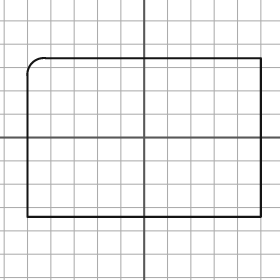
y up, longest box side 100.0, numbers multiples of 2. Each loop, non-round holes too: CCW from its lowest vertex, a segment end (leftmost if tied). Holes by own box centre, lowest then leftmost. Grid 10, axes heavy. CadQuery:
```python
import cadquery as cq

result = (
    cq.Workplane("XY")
    .moveTo(-50.0, -34.0)
    .lineTo(50.0, -34.0)
    .lineTo(50.0, 34.0)
    .lineTo(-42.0, 34.0)
    .threePointArc((-48.0, 32.0), (-50.0, 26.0))
    .close()
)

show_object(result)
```